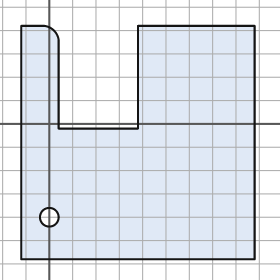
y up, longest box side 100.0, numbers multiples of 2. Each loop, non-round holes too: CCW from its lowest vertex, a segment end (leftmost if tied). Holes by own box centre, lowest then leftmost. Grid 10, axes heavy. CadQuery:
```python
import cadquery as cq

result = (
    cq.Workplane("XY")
    .moveTo(-12.0, -58.0)
    .lineTo(88.0, -58.0)
    .lineTo(88.0, 42.0)
    .lineTo(38.0, 42.0)
    .lineTo(38.0, -2.0)
    .lineTo(4.0, -2.0)
    .lineTo(4.0, 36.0)
    .threePointArc((2.0, 40.0), (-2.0, 42.0))
    .lineTo(-12.0, 42.0)
    .close()
    .moveTo(0.0, -40.0)
    .circle(4.0)
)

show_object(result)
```